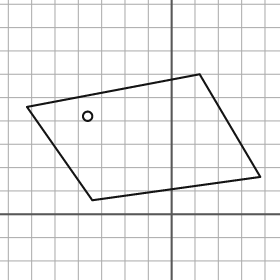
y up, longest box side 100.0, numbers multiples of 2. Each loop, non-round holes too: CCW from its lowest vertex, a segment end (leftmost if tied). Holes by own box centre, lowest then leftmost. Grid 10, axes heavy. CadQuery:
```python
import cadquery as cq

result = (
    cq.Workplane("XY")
    .moveTo(-34.0, 6.0)
    .lineTo(38.0, 16.0)
    .lineTo(12.0, 60.0)
    .lineTo(-62.0, 46.0)
    .close()
    .moveTo(-36.0, 42.0)
    .circle(2.0)
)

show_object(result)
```